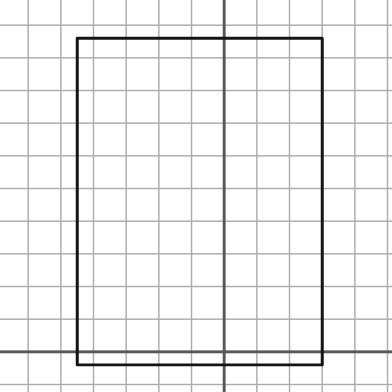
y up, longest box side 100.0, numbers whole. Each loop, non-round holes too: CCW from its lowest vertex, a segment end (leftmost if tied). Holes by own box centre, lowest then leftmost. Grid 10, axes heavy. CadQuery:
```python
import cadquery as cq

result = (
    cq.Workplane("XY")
    .moveTo(-45.0, -4.0)
    .lineTo(30.0, -4.0)
    .lineTo(30.0, 96.0)
    .lineTo(-45.0, 96.0)
    .close()
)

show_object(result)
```